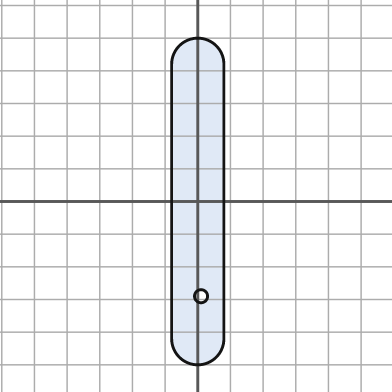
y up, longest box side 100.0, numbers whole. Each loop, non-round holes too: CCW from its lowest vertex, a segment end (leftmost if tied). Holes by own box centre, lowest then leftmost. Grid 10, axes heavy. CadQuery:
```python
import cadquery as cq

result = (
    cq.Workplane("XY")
    .moveTo(-8.0, -42.0)
    .threePointArc((0.0, -50.0), (8.0, -42.0))
    .lineTo(8.0, 42.0)
    .threePointArc((0.0, 50.0), (-8.0, 42.0))
    .close()
    .moveTo(1.0, -29.0)
    .circle(2.0)
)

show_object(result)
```